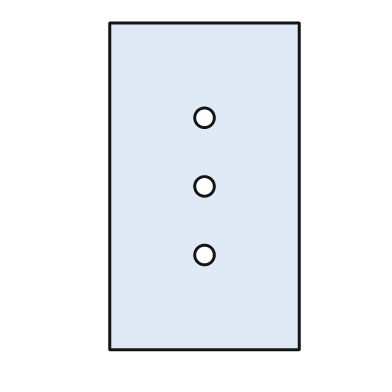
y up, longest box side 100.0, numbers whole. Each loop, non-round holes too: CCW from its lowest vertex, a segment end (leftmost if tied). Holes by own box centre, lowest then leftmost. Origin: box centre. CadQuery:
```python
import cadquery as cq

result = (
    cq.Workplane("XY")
    .moveTo(-29.0, -50.0)
    .lineTo(29.0, -50.0)
    .lineTo(29.0, 50.0)
    .lineTo(-29.0, 50.0)
    .close()
    .moveTo(0.0, -21.0)
    .circle(3.0)
    .moveTo(0.0, 0.0)
    .circle(3.0)
    .moveTo(0.0, 21.0)
    .circle(3.0)
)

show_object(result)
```